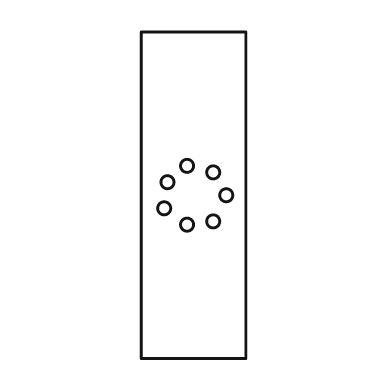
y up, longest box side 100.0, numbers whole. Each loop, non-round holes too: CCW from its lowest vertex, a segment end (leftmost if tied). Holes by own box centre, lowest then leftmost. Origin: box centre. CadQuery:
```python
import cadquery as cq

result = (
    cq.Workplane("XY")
    .moveTo(-16.0, -50.0)
    .lineTo(16.0, -50.0)
    .lineTo(16.0, 50.0)
    .lineTo(-16.0, 50.0)
    .close()
    .moveTo(-2.0, -9.0)
    .circle(2.0)
    .moveTo(6.0, -8.0)
    .circle(2.0)
    .moveTo(-9.0, -4.0)
    .circle(2.0)
    .moveTo(10.0, 0.0)
    .circle(2.0)
    .moveTo(-8.0, 4.0)
    .circle(2.0)
    .moveTo(6.0, 7.0)
    .circle(2.0)
    .moveTo(-2.0, 9.0)
    .circle(2.0)
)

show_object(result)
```